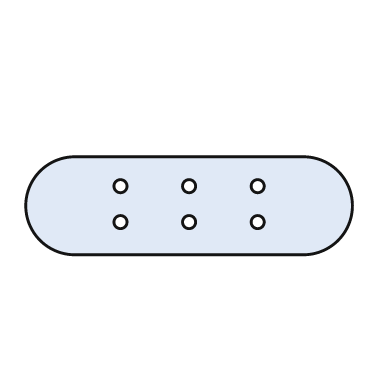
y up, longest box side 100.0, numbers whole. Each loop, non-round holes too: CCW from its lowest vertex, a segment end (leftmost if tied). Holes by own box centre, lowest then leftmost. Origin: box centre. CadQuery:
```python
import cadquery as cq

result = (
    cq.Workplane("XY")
    .moveTo(-35.0, -15.0)
    .lineTo(35.0, -15.0)
    .threePointArc((50.0, 0.0), (35.0, 15.0))
    .lineTo(-35.0, 15.0)
    .threePointArc((-50.0, 0.0), (-35.0, -15.0))
    .close()
    .moveTo(-21.0, -5.0)
    .circle(2.0)
    .moveTo(0.0, -5.0)
    .circle(2.0)
    .moveTo(21.0, -5.0)
    .circle(2.0)
    .moveTo(-21.0, 6.0)
    .circle(2.0)
    .moveTo(0.0, 6.0)
    .circle(2.0)
    .moveTo(21.0, 6.0)
    .circle(2.0)
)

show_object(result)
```